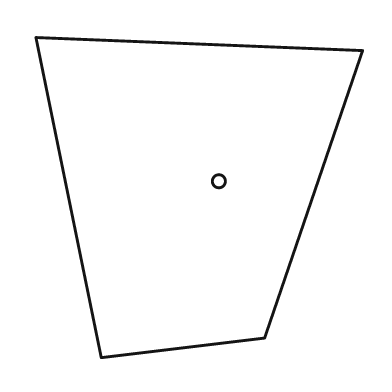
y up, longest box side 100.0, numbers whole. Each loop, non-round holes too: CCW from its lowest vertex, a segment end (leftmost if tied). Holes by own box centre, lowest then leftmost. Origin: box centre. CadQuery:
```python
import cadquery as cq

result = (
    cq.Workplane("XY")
    .moveTo(-30.0, -49.0)
    .lineTo(20.0, -43.0)
    .lineTo(50.0, 45.0)
    .lineTo(-50.0, 49.0)
    .close()
    .moveTo(6.0, 5.0)
    .circle(2.0)
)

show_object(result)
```